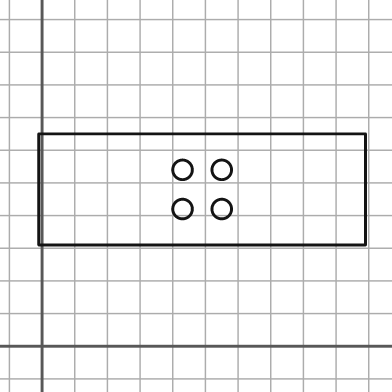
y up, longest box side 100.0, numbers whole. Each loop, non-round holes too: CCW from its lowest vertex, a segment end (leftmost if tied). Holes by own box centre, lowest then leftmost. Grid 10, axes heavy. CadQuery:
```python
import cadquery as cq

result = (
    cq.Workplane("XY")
    .moveTo(-1.0, 31.0)
    .lineTo(99.0, 31.0)
    .lineTo(99.0, 65.0)
    .lineTo(-1.0, 65.0)
    .close()
    .moveTo(43.0, 42.0)
    .circle(3.0)
    .moveTo(55.0, 42.0)
    .circle(3.0)
    .moveTo(43.0, 54.0)
    .circle(3.0)
    .moveTo(55.0, 54.0)
    .circle(3.0)
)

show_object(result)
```